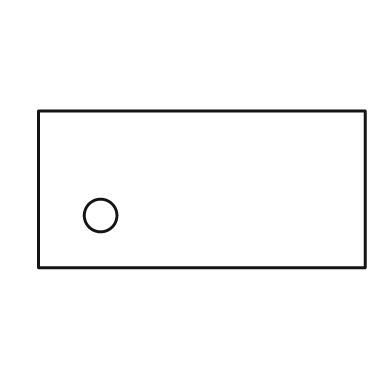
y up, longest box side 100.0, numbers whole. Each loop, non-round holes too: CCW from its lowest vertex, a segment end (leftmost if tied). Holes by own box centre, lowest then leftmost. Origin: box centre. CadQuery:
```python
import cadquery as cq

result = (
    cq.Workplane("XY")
    .moveTo(-50.0, -24.0)
    .lineTo(50.0, -24.0)
    .lineTo(50.0, 24.0)
    .lineTo(-50.0, 24.0)
    .close()
    .moveTo(-31.0, -8.0)
    .circle(5.0)
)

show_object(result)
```